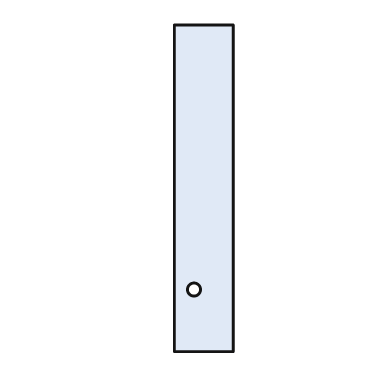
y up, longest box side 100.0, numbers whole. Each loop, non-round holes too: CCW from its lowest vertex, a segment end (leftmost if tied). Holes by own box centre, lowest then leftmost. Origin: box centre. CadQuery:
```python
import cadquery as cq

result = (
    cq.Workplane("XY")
    .moveTo(-9.0, -50.0)
    .lineTo(9.0, -50.0)
    .lineTo(9.0, 50.0)
    .lineTo(-9.0, 50.0)
    .close()
    .moveTo(-3.0, -31.0)
    .circle(2.0)
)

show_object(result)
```